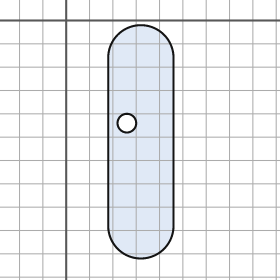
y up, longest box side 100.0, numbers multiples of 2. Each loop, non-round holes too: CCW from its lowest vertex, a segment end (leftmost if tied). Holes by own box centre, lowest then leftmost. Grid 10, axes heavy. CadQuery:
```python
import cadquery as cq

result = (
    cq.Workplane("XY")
    .moveTo(18.0, -88.0)
    .threePointArc((32.0, -102.0), (46.0, -88.0))
    .lineTo(46.0, -16.0)
    .threePointArc((32.0, -2.0), (18.0, -16.0))
    .close()
    .moveTo(26.0, -44.0)
    .circle(4.0)
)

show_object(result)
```